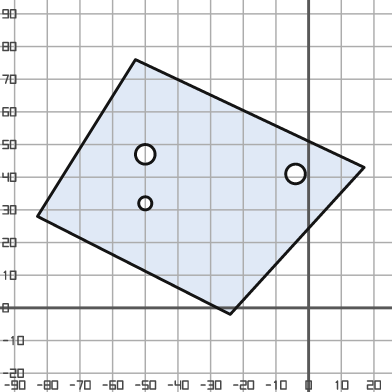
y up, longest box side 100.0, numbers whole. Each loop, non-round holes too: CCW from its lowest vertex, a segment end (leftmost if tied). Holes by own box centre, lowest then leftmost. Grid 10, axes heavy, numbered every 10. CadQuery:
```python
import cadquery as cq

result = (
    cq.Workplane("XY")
    .moveTo(-24.0, -2.0)
    .lineTo(17.0, 43.0)
    .lineTo(-53.0, 76.0)
    .lineTo(-83.0, 28.0)
    .close()
    .moveTo(-50.0, 32.0)
    .circle(2.0)
    .moveTo(-4.0, 41.0)
    .circle(3.0)
    .moveTo(-50.0, 47.0)
    .circle(3.0)
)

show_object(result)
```